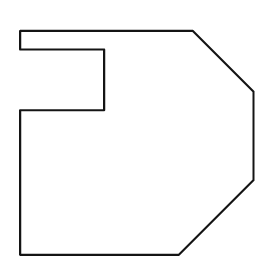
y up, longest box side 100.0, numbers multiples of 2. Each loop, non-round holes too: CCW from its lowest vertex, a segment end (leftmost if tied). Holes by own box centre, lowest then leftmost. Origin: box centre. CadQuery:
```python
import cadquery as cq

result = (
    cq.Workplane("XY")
    .moveTo(-50.0, -48.0)
    .lineTo(18.0, -48.0)
    .lineTo(50.0, -16.0)
    .lineTo(50.0, 22.0)
    .lineTo(24.0, 48.0)
    .lineTo(-50.0, 48.0)
    .lineTo(-50.0, 40.0)
    .lineTo(-14.0, 40.0)
    .lineTo(-14.0, 14.0)
    .lineTo(-50.0, 14.0)
    .close()
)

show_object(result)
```